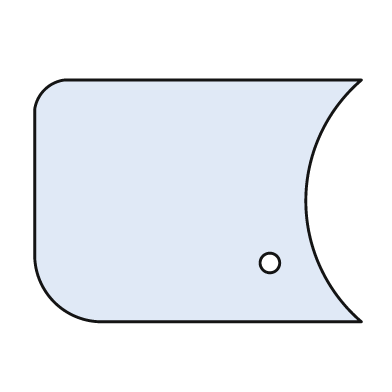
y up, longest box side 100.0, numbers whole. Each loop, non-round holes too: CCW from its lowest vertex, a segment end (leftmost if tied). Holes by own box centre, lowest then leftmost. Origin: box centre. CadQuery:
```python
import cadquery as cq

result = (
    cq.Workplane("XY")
    .moveTo(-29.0, -37.0)
    .lineTo(50.0, -37.0)
    .threePointArc((33.0, 0.0), (50.0, 37.0))
    .lineTo(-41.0, 37.0)
    .threePointArc((-47.0, 34.0), (-50.0, 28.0))
    .lineTo(-50.0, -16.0)
    .threePointArc((-44.0, -31.0), (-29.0, -37.0))
    .close()
    .moveTo(22.0, -19.0)
    .circle(3.0)
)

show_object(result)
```